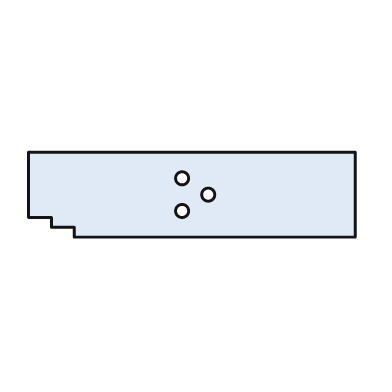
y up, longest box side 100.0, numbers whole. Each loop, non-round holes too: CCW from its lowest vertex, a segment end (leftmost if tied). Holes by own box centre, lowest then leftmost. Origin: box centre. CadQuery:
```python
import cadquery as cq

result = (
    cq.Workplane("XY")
    .moveTo(-36.0, -13.0)
    .lineTo(50.0, -13.0)
    .lineTo(50.0, 13.0)
    .lineTo(-50.0, 13.0)
    .lineTo(-50.0, -7.0)
    .lineTo(-43.0, -7.0)
    .lineTo(-43.0, -10.0)
    .lineTo(-36.0, -10.0)
    .close()
    .moveTo(-3.0, -5.0)
    .circle(2.0)
    .moveTo(5.0, 0.0)
    .circle(2.0)
    .moveTo(-3.0, 5.0)
    .circle(2.0)
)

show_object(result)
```